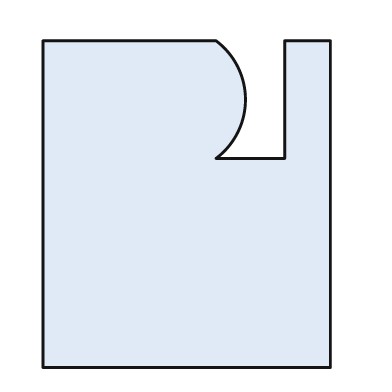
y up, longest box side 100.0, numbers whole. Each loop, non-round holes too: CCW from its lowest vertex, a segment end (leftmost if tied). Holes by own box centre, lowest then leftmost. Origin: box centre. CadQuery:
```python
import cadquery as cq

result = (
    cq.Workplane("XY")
    .moveTo(-44.0, -50.0)
    .lineTo(44.0, -50.0)
    .lineTo(44.0, 50.0)
    .lineTo(30.0, 50.0)
    .lineTo(30.0, 14.0)
    .lineTo(9.0, 14.0)
    .threePointArc((18.0, 32.0), (9.0, 50.0))
    .lineTo(-44.0, 50.0)
    .close()
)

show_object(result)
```